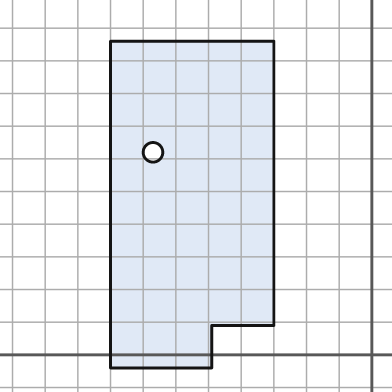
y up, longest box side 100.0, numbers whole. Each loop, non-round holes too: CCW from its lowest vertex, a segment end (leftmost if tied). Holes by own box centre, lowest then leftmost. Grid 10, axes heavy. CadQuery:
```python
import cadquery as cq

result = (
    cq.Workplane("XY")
    .moveTo(-80.0, -4.0)
    .lineTo(-49.0, -4.0)
    .lineTo(-49.0, 9.0)
    .lineTo(-30.0, 9.0)
    .lineTo(-30.0, 96.0)
    .lineTo(-80.0, 96.0)
    .close()
    .moveTo(-67.0, 62.0)
    .circle(3.0)
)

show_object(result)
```